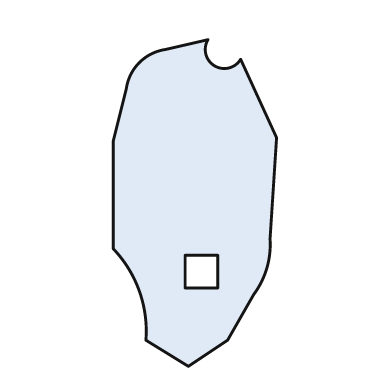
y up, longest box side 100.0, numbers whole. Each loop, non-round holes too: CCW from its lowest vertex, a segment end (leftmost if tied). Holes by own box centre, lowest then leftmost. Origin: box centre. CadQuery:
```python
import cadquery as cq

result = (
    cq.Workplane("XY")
    .moveTo(-2.0, -50.0)
    .lineTo(10.0, -42.0)
    .lineTo(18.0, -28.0)
    .threePointArc((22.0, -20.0), (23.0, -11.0))
    .lineTo(25.0, 20.0)
    .lineTo(14.0, 44.0)
    .threePointArc((6.0, 42.0), (4.0, 50.0))
    .lineTo(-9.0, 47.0)
    .threePointArc((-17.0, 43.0), (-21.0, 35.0))
    .lineTo(-25.0, 19.0)
    .lineTo(-25.0, -14.0)
    .threePointArc((-17.0, -27.0), (-15.0, -42.0))
    .close()
    .moveTo(-3.0, -26.0)
    .lineTo(7.0, -26.0)
    .lineTo(7.0, -16.0)
    .lineTo(-3.0, -16.0)
    .close()
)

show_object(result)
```